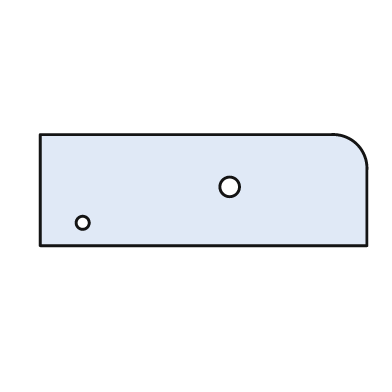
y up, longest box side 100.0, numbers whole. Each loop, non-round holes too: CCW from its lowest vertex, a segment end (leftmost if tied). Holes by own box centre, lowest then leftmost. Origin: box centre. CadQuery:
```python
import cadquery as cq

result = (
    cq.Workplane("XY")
    .moveTo(-50.0, -17.0)
    .lineTo(50.0, -17.0)
    .lineTo(50.0, 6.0)
    .threePointArc((47.0, 14.0), (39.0, 17.0))
    .lineTo(-50.0, 17.0)
    .close()
    .moveTo(-37.0, -10.0)
    .circle(2.0)
    .moveTo(8.0, 1.0)
    .circle(3.0)
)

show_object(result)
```